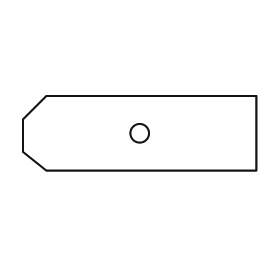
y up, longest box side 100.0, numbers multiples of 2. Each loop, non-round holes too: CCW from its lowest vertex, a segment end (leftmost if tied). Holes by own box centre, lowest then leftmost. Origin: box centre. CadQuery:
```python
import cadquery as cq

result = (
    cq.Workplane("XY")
    .moveTo(-40.0, -16.0)
    .lineTo(50.0, -16.0)
    .lineTo(50.0, 16.0)
    .lineTo(-40.0, 16.0)
    .lineTo(-50.0, 6.0)
    .lineTo(-50.0, -8.0)
    .close()
    .moveTo(0.0, 0.0)
    .circle(4.0)
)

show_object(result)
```